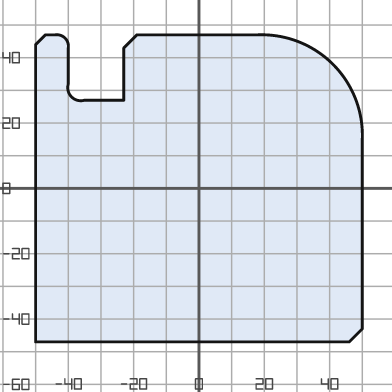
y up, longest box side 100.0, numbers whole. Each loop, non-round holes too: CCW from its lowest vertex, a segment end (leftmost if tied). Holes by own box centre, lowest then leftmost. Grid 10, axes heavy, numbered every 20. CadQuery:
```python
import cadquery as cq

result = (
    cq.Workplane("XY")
    .moveTo(-50.0, -47.0)
    .lineTo(46.0, -47.0)
    .lineTo(50.0, -43.0)
    .lineTo(50.0, 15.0)
    .threePointArc((41.0, 38.0), (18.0, 47.0))
    .lineTo(-19.0, 47.0)
    .lineTo(-23.0, 43.0)
    .lineTo(-23.0, 27.0)
    .lineTo(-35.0, 27.0)
    .threePointArc((-39.0, 28.0), (-40.0, 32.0))
    .lineTo(-40.0, 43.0)
    .threePointArc((-41.0, 46.0), (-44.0, 47.0))
    .lineTo(-47.0, 47.0)
    .lineTo(-50.0, 44.0)
    .close()
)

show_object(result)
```